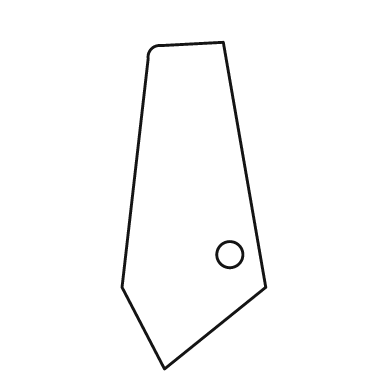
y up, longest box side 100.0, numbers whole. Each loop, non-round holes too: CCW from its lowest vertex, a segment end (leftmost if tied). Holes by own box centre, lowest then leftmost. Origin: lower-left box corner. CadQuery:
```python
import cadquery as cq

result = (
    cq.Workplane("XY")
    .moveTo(13.0, 0.0)
    .lineTo(44.0, 25.0)
    .lineTo(31.0, 100.0)
    .lineTo(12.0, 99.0)
    .threePointArc((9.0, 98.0), (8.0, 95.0))
    .lineTo(0.0, 25.0)
    .close()
    .moveTo(33.0, 35.0)
    .circle(4.0)
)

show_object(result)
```